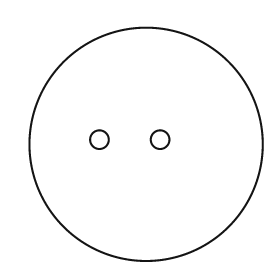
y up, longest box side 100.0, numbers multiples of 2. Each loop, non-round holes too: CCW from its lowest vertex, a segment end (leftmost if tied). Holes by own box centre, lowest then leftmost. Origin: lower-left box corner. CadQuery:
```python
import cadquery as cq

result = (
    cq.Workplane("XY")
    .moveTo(50.0, 50.0)
    .circle(50.0)
    .moveTo(30.0, 52.0)
    .circle(4.0)
    .moveTo(56.0, 52.0)
    .circle(4.0)
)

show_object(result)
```